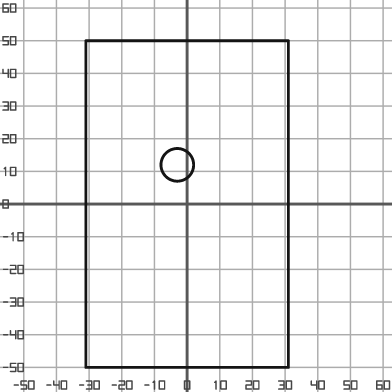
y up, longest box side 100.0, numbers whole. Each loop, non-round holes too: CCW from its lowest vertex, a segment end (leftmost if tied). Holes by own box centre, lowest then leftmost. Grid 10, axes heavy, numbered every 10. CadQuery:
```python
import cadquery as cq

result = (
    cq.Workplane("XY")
    .moveTo(-31.0, -50.0)
    .lineTo(31.0, -50.0)
    .lineTo(31.0, 50.0)
    .lineTo(-31.0, 50.0)
    .close()
    .moveTo(-3.0, 12.0)
    .circle(5.0)
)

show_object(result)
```